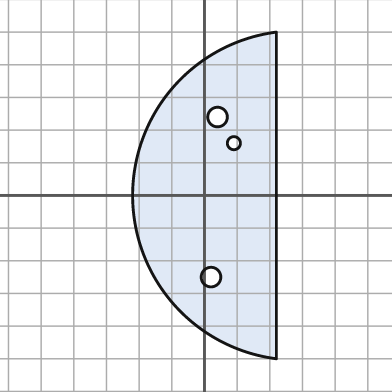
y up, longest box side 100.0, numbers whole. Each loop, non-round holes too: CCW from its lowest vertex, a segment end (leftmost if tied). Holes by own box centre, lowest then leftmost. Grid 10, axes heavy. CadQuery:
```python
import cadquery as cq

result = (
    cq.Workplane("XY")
    .moveTo(22.0, -50.0)
    .lineTo(22.0, 50.0)
    .threePointArc((-22.0, 0.0), (22.0, -50.0))
    .close()
    .moveTo(2.0, -25.0)
    .circle(3.0)
    .moveTo(9.0, 16.0)
    .circle(2.0)
    .moveTo(4.0, 24.0)
    .circle(3.0)
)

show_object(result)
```